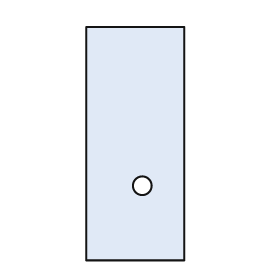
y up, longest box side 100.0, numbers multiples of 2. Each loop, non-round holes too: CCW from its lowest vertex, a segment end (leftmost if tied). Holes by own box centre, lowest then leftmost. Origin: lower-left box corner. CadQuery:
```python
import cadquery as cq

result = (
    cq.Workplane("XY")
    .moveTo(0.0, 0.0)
    .lineTo(42.0, 0.0)
    .lineTo(42.0, 100.0)
    .lineTo(0.0, 100.0)
    .close()
    .moveTo(24.0, 32.0)
    .circle(4.0)
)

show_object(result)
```